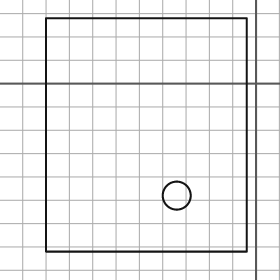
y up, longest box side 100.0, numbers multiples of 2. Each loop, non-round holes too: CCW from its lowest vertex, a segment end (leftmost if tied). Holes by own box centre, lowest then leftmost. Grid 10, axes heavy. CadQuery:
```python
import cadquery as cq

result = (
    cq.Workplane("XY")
    .moveTo(-90.0, -72.0)
    .lineTo(-4.0, -72.0)
    .lineTo(-4.0, 28.0)
    .lineTo(-90.0, 28.0)
    .close()
    .moveTo(-34.0, -48.0)
    .circle(6.0)
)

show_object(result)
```